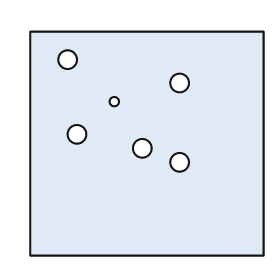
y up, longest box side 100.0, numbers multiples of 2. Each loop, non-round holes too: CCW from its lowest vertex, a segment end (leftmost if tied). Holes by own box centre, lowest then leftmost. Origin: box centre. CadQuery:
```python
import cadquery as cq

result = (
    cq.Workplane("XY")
    .moveTo(-50.0, -48.0)
    .lineTo(50.0, -48.0)
    .lineTo(50.0, 48.0)
    .lineTo(-50.0, 48.0)
    .close()
    .moveTo(14.0, -8.0)
    .circle(4.0)
    .moveTo(-2.0, -2.0)
    .circle(4.0)
    .moveTo(-30.0, 4.0)
    .circle(4.0)
    .moveTo(-14.0, 18.0)
    .circle(2.0)
    .moveTo(14.0, 26.0)
    .circle(4.0)
    .moveTo(-34.0, 36.0)
    .circle(4.0)
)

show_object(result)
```